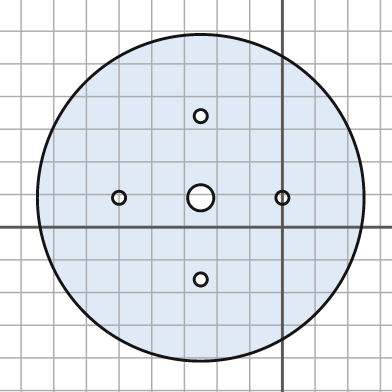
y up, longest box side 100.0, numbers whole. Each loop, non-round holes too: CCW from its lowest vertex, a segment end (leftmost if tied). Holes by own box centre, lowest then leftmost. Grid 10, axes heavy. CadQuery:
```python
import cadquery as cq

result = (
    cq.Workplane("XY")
    .moveTo(-25.0, 9.0)
    .circle(50.0)
    .moveTo(-25.0, -16.0)
    .circle(2.0)
    .moveTo(-50.0, 9.0)
    .circle(2.0)
    .moveTo(-25.0, 9.0)
    .circle(4.0)
    .moveTo(0.0, 9.0)
    .circle(2.0)
    .moveTo(-25.0, 34.0)
    .circle(2.0)
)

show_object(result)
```